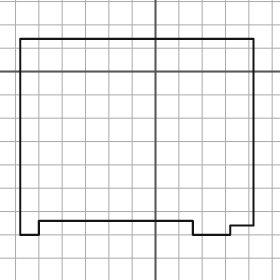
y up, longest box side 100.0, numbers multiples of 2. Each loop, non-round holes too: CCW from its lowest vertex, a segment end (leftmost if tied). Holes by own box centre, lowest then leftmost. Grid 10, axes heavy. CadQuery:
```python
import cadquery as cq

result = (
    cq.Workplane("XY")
    .moveTo(-58.0, -70.0)
    .lineTo(-50.0, -70.0)
    .lineTo(-50.0, -64.0)
    .lineTo(16.0, -64.0)
    .lineTo(16.0, -70.0)
    .lineTo(32.0, -70.0)
    .lineTo(32.0, -66.0)
    .lineTo(42.0, -66.0)
    .lineTo(42.0, 14.0)
    .lineTo(-58.0, 14.0)
    .close()
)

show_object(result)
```